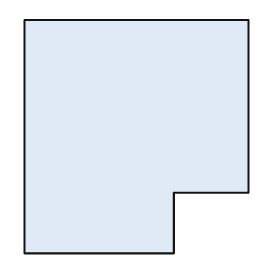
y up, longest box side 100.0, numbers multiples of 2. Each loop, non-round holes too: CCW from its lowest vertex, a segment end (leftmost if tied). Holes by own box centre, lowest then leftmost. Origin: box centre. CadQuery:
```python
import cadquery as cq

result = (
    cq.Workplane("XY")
    .moveTo(-48.0, -50.0)
    .lineTo(16.0, -50.0)
    .lineTo(16.0, -24.0)
    .lineTo(48.0, -24.0)
    .lineTo(48.0, 50.0)
    .lineTo(-48.0, 50.0)
    .close()
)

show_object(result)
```